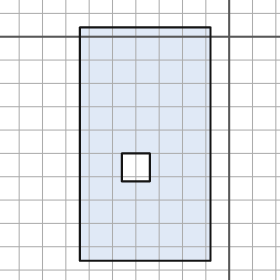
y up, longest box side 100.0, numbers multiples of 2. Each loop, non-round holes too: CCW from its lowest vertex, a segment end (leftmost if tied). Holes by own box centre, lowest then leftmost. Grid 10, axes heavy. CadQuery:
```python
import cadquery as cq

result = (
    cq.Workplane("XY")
    .moveTo(-64.0, -96.0)
    .lineTo(-8.0, -96.0)
    .lineTo(-8.0, 4.0)
    .lineTo(-64.0, 4.0)
    .close()
    .moveTo(-46.0, -62.0)
    .lineTo(-34.0, -62.0)
    .lineTo(-34.0, -50.0)
    .lineTo(-46.0, -50.0)
    .close()
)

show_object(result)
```